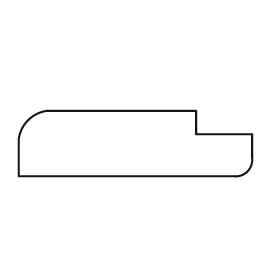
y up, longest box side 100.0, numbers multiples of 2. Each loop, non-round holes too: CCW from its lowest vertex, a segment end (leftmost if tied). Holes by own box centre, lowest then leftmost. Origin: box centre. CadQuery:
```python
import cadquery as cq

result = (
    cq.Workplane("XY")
    .moveTo(-50.0, -14.0)
    .lineTo(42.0, -14.0)
    .threePointArc((48.0, -12.0), (50.0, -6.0))
    .lineTo(50.0, 4.0)
    .lineTo(26.0, 4.0)
    .lineTo(26.0, 14.0)
    .lineTo(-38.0, 14.0)
    .threePointArc((-46.0, 10.0), (-50.0, 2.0))
    .close()
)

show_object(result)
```